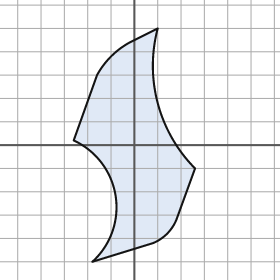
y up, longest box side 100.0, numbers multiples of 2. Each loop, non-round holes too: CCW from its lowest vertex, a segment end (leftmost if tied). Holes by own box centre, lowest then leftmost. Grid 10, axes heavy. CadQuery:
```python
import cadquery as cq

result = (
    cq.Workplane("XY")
    .moveTo(-18.0, -50.0)
    .lineTo(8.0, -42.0)
    .threePointArc((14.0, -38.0), (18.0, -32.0))
    .lineTo(26.0, -10.0)
    .threePointArc((10.0, 18.0), (10.0, 50.0))
    .lineTo(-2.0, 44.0)
    .threePointArc((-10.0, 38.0), (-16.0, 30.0))
    .lineTo(-26.0, 2.0)
    .threePointArc((-8.0, -22.0), (-18.0, -50.0))
    .close()
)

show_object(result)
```